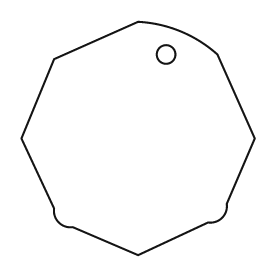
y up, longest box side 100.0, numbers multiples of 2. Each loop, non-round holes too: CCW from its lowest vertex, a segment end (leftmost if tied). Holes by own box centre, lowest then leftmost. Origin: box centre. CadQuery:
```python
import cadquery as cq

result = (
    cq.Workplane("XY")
    .moveTo(0.0, -50.0)
    .lineTo(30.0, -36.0)
    .threePointArc((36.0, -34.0), (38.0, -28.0))
    .lineTo(50.0, 0.0)
    .lineTo(34.0, 36.0)
    .threePointArc((18.0, 46.0), (0.0, 50.0))
    .lineTo(-36.0, 34.0)
    .lineTo(-50.0, 0.0)
    .lineTo(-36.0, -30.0)
    .threePointArc((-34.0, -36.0), (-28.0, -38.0))
    .close()
    .moveTo(12.0, 36.0)
    .circle(4.0)
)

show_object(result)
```